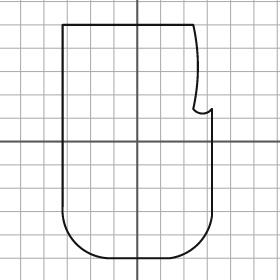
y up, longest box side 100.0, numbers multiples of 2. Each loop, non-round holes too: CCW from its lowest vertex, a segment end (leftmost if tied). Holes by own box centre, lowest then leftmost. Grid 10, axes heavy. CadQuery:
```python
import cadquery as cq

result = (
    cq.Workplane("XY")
    .moveTo(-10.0, -50.0)
    .lineTo(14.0, -50.0)
    .threePointArc((26.0, -44.0), (32.0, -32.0))
    .lineTo(32.0, 14.0)
    .threePointArc((28.0, 12.0), (24.0, 14.0))
    .threePointArc((26.0, 32.0), (24.0, 50.0))
    .lineTo(-32.0, 50.0)
    .lineTo(-32.0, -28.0)
    .threePointArc((-26.0, -44.0), (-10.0, -50.0))
    .close()
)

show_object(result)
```